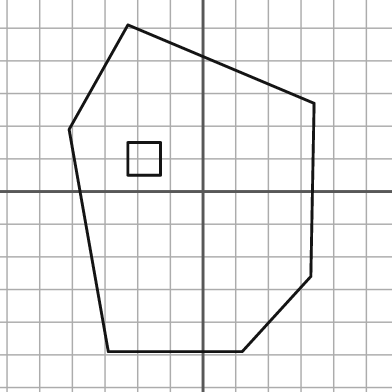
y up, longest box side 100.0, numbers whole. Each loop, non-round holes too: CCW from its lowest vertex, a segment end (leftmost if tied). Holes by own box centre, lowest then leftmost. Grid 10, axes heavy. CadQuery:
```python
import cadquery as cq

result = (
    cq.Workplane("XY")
    .moveTo(-29.0, -49.0)
    .lineTo(12.0, -49.0)
    .lineTo(33.0, -26.0)
    .lineTo(34.0, 27.0)
    .lineTo(-23.0, 51.0)
    .lineTo(-41.0, 19.0)
    .close()
    .moveTo(-23.0, 5.0)
    .lineTo(-13.0, 5.0)
    .lineTo(-13.0, 15.0)
    .lineTo(-23.0, 15.0)
    .close()
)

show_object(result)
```